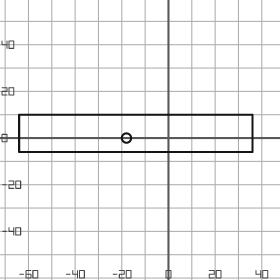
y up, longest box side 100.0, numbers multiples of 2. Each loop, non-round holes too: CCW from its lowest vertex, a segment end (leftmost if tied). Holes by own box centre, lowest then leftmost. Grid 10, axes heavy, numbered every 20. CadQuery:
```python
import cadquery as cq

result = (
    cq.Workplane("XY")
    .moveTo(-64.0, -6.0)
    .lineTo(36.0, -6.0)
    .lineTo(36.0, 10.0)
    .lineTo(-64.0, 10.0)
    .close()
    .moveTo(-18.0, 0.0)
    .circle(2.0)
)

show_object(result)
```